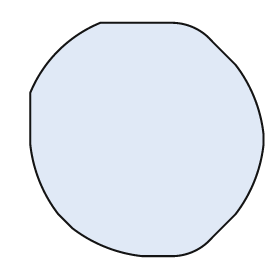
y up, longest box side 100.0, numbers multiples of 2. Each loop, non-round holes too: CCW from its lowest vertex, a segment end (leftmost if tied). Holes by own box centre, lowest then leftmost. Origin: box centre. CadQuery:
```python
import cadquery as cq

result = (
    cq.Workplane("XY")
    .moveTo(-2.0, -50.0)
    .lineTo(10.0, -50.0)
    .threePointArc((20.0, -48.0), (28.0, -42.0))
    .lineTo(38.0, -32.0)
    .threePointArc((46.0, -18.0), (50.0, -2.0))
    .lineTo(50.0, 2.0)
    .threePointArc((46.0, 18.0), (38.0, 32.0))
    .lineTo(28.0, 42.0)
    .threePointArc((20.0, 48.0), (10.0, 50.0))
    .lineTo(-20.0, 50.0)
    .threePointArc((-38.0, 38.0), (-50.0, 20.0))
    .lineTo(-50.0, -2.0)
    .threePointArc((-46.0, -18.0), (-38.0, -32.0))
    .lineTo(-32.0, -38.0)
    .threePointArc((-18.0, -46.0), (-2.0, -50.0))
    .close()
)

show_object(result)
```